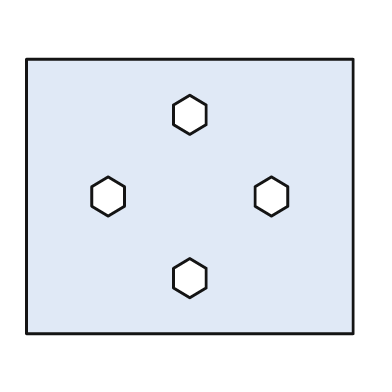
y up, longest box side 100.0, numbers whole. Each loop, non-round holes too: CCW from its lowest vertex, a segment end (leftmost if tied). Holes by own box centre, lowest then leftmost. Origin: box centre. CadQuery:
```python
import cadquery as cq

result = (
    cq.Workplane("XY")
    .moveTo(-50.0, -42.0)
    .lineTo(50.0, -42.0)
    .lineTo(50.0, 42.0)
    .lineTo(-50.0, 42.0)
    .close()
    .moveTo(0.0, -31.0)
    .lineTo(5.0, -28.0)
    .lineTo(5.0, -22.0)
    .lineTo(0.0, -19.0)
    .lineTo(-5.0, -22.0)
    .lineTo(-5.0, -28.0)
    .close()
    .moveTo(-25.0, -6.0)
    .lineTo(-20.0, -3.0)
    .lineTo(-20.0, 3.0)
    .lineTo(-25.0, 6.0)
    .lineTo(-30.0, 3.0)
    .lineTo(-30.0, -3.0)
    .close()
    .moveTo(25.0, -6.0)
    .lineTo(30.0, -3.0)
    .lineTo(30.0, 3.0)
    .lineTo(25.0, 6.0)
    .lineTo(20.0, 3.0)
    .lineTo(20.0, -3.0)
    .close()
    .moveTo(0.0, 19.0)
    .lineTo(5.0, 22.0)
    .lineTo(5.0, 28.0)
    .lineTo(0.0, 31.0)
    .lineTo(-5.0, 28.0)
    .lineTo(-5.0, 22.0)
    .close()
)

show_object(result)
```